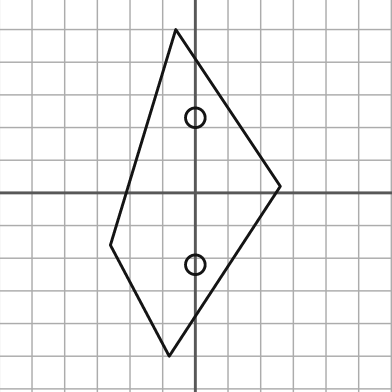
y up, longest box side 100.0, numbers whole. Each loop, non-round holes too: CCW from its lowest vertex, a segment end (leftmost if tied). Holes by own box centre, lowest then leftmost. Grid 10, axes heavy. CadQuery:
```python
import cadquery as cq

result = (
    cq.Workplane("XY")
    .moveTo(-8.0, -50.0)
    .lineTo(26.0, 2.0)
    .lineTo(-6.0, 50.0)
    .lineTo(-26.0, -16.0)
    .close()
    .moveTo(0.0, -22.0)
    .circle(3.0)
    .moveTo(0.0, 23.0)
    .circle(3.0)
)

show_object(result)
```